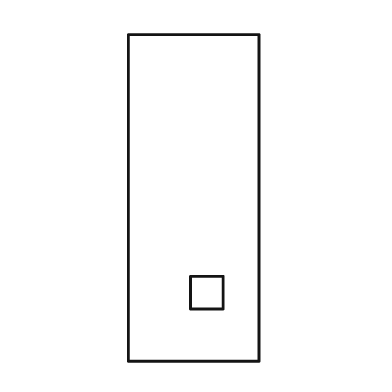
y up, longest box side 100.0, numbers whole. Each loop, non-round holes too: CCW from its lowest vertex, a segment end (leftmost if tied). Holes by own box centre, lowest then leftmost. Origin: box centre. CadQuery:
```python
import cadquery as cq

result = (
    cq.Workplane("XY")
    .moveTo(-20.0, -50.0)
    .lineTo(20.0, -50.0)
    .lineTo(20.0, 50.0)
    .lineTo(-20.0, 50.0)
    .close()
    .moveTo(-1.0, -34.0)
    .lineTo(9.0, -34.0)
    .lineTo(9.0, -24.0)
    .lineTo(-1.0, -24.0)
    .close()
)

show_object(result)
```